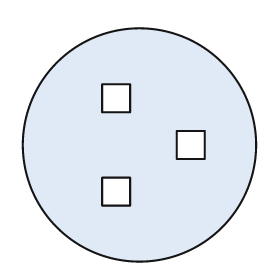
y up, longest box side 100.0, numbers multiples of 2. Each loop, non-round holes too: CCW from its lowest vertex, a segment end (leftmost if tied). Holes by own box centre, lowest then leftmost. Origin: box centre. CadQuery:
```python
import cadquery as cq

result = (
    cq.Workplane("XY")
    .moveTo(0.0, 0.0)
    .circle(50.0)
    .moveTo(-16.0, -26.0)
    .lineTo(-4.0, -26.0)
    .lineTo(-4.0, -14.0)
    .lineTo(-16.0, -14.0)
    .close()
    .moveTo(16.0, -6.0)
    .lineTo(28.0, -6.0)
    .lineTo(28.0, 6.0)
    .lineTo(16.0, 6.0)
    .close()
    .moveTo(-16.0, 14.0)
    .lineTo(-4.0, 14.0)
    .lineTo(-4.0, 26.0)
    .lineTo(-16.0, 26.0)
    .close()
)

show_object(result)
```